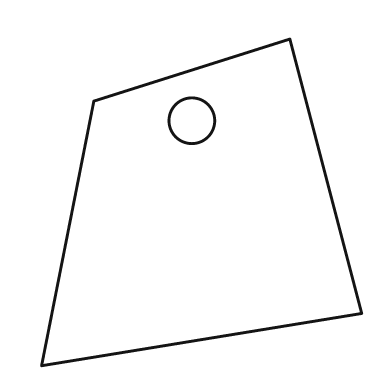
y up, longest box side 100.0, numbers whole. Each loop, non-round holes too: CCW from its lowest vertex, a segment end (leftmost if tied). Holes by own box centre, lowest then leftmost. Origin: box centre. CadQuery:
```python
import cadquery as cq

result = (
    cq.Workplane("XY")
    .moveTo(-49.0, -50.0)
    .lineTo(49.0, -34.0)
    .lineTo(27.0, 50.0)
    .lineTo(-33.0, 31.0)
    .close()
    .moveTo(-3.0, 25.0)
    .circle(7.0)
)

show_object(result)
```